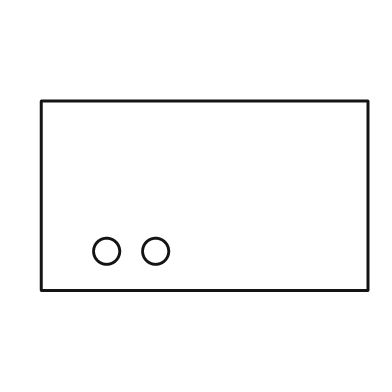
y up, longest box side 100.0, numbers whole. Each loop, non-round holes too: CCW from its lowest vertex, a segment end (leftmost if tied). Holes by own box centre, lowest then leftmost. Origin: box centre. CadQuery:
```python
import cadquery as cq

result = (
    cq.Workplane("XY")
    .moveTo(-50.0, -29.0)
    .lineTo(50.0, -29.0)
    .lineTo(50.0, 29.0)
    .lineTo(-50.0, 29.0)
    .close()
    .moveTo(-30.0, -17.0)
    .circle(4.0)
    .moveTo(-15.0, -17.0)
    .circle(4.0)
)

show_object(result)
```